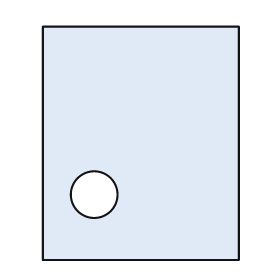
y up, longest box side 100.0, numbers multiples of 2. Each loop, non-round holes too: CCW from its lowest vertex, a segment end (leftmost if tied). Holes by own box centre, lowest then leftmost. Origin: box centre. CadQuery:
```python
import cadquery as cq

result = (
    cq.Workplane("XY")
    .moveTo(-42.0, -50.0)
    .lineTo(42.0, -50.0)
    .lineTo(42.0, 50.0)
    .lineTo(-42.0, 50.0)
    .close()
    .moveTo(-20.0, -22.0)
    .circle(10.0)
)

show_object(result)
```